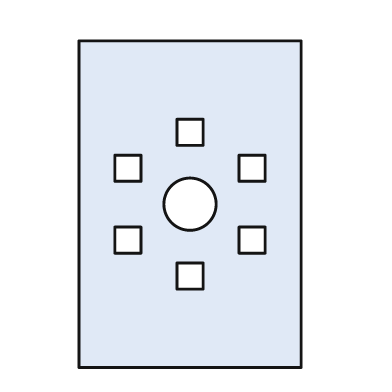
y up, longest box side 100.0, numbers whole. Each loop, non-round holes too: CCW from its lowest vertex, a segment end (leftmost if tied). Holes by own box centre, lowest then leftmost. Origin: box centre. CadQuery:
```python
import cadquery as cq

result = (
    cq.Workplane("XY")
    .moveTo(-34.0, -50.0)
    .lineTo(34.0, -50.0)
    .lineTo(34.0, 50.0)
    .lineTo(-34.0, 50.0)
    .close()
    .moveTo(-4.0, -26.0)
    .lineTo(4.0, -26.0)
    .lineTo(4.0, -18.0)
    .lineTo(-4.0, -18.0)
    .close()
    .moveTo(-23.0, -15.0)
    .lineTo(-15.0, -15.0)
    .lineTo(-15.0, -7.0)
    .lineTo(-23.0, -7.0)
    .close()
    .moveTo(15.0, -15.0)
    .lineTo(23.0, -15.0)
    .lineTo(23.0, -7.0)
    .lineTo(15.0, -7.0)
    .close()
    .moveTo(0.0, 0.0)
    .circle(8.0)
    .moveTo(-23.0, 7.0)
    .lineTo(-15.0, 7.0)
    .lineTo(-15.0, 15.0)
    .lineTo(-23.0, 15.0)
    .close()
    .moveTo(15.0, 7.0)
    .lineTo(23.0, 7.0)
    .lineTo(23.0, 15.0)
    .lineTo(15.0, 15.0)
    .close()
    .moveTo(-4.0, 18.0)
    .lineTo(4.0, 18.0)
    .lineTo(4.0, 26.0)
    .lineTo(-4.0, 26.0)
    .close()
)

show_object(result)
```